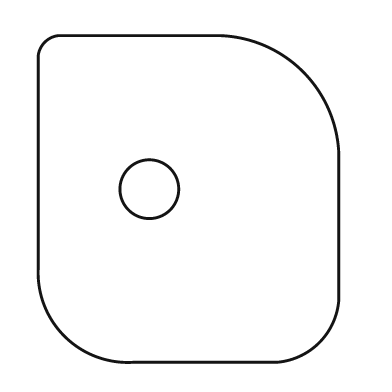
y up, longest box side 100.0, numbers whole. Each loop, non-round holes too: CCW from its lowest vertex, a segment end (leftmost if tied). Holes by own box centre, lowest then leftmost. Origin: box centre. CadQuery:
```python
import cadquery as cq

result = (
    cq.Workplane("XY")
    .moveTo(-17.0, -50.0)
    .lineTo(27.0, -50.0)
    .threePointArc((40.0, -44.0), (46.0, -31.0))
    .lineTo(46.0, 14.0)
    .threePointArc((35.0, 39.0), (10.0, 50.0))
    .lineTo(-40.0, 50.0)
    .threePointArc((-44.0, 48.0), (-46.0, 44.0))
    .lineTo(-46.0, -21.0)
    .threePointArc((-38.0, -42.0), (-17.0, -50.0))
    .close()
    .moveTo(-12.0, 3.0)
    .circle(9.0)
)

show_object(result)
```